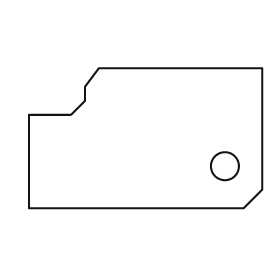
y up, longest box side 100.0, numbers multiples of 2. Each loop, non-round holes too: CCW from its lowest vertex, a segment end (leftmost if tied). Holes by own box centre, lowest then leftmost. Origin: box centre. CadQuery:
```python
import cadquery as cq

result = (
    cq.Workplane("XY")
    .moveTo(-50.0, -30.0)
    .lineTo(42.0, -30.0)
    .lineTo(50.0, -22.0)
    .lineTo(50.0, 30.0)
    .lineTo(-20.0, 30.0)
    .lineTo(-26.0, 22.0)
    .lineTo(-26.0, 16.0)
    .lineTo(-32.0, 10.0)
    .lineTo(-50.0, 10.0)
    .close()
    .moveTo(34.0, -12.0)
    .circle(6.0)
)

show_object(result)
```